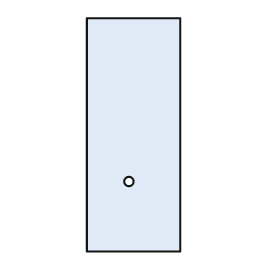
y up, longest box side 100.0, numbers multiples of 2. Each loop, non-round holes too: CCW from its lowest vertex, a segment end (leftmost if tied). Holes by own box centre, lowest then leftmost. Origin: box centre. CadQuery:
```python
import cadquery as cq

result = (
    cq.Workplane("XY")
    .moveTo(-20.0, -50.0)
    .lineTo(20.0, -50.0)
    .lineTo(20.0, 50.0)
    .lineTo(-20.0, 50.0)
    .close()
    .moveTo(-2.0, -20.0)
    .circle(2.0)
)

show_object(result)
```